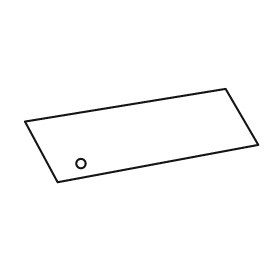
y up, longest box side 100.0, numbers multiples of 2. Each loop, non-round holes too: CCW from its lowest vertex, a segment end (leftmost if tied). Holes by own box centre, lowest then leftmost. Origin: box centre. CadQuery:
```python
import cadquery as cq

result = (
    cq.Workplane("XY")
    .moveTo(-36.0, -20.0)
    .lineTo(50.0, -4.0)
    .lineTo(36.0, 20.0)
    .lineTo(-50.0, 6.0)
    .close()
    .moveTo(-26.0, -12.0)
    .circle(2.0)
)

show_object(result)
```